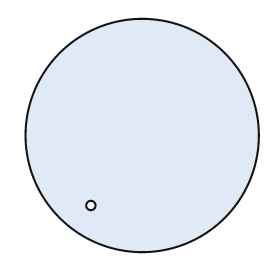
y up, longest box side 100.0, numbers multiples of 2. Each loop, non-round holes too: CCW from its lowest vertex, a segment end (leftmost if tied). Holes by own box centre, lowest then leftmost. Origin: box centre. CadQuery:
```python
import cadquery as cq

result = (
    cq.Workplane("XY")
    .moveTo(0.0, 0.0)
    .circle(50.0)
    .moveTo(-22.0, -30.0)
    .circle(2.0)
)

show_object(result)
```